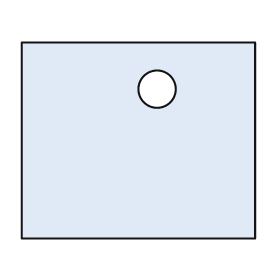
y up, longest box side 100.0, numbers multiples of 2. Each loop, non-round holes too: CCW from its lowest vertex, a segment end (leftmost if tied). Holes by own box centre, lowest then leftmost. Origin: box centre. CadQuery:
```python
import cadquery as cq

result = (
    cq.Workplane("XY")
    .moveTo(-50.0, -42.0)
    .lineTo(50.0, -42.0)
    .lineTo(50.0, 42.0)
    .lineTo(-50.0, 42.0)
    .close()
    .moveTo(8.0, 22.0)
    .circle(8.0)
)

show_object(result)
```